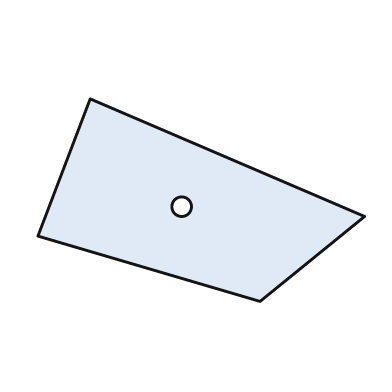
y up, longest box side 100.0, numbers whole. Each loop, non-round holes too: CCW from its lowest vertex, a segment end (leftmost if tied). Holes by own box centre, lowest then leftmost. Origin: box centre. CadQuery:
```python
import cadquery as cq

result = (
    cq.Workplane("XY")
    .moveTo(18.0, -31.0)
    .lineTo(50.0, -5.0)
    .lineTo(-34.0, 31.0)
    .lineTo(-50.0, -11.0)
    .close()
    .moveTo(-6.0, -2.0)
    .circle(3.0)
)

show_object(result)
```